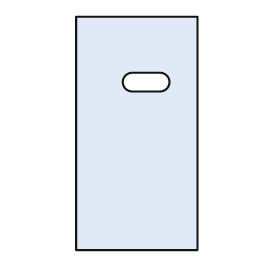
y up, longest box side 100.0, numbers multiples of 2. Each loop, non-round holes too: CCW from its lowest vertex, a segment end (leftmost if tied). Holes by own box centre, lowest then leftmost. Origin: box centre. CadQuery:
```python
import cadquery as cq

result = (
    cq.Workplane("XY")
    .moveTo(-26.0, -50.0)
    .lineTo(26.0, -50.0)
    .lineTo(26.0, 50.0)
    .lineTo(-26.0, 50.0)
    .close()
    .moveTo(-2.0, 18.0)
    .lineTo(10.0, 18.0)
    .threePointArc((14.0, 22.0), (10.0, 26.0))
    .lineTo(-2.0, 26.0)
    .threePointArc((-6.0, 22.0), (-2.0, 18.0))
    .close()
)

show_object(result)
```